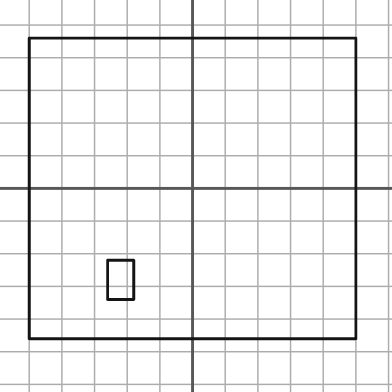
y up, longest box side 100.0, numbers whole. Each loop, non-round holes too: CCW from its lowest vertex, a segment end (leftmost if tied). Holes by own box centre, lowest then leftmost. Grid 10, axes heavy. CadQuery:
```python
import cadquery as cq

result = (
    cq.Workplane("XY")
    .moveTo(-50.0, -46.0)
    .lineTo(50.0, -46.0)
    .lineTo(50.0, 46.0)
    .lineTo(-50.0, 46.0)
    .close()
    .moveTo(-26.0, -34.0)
    .lineTo(-18.0, -34.0)
    .lineTo(-18.0, -22.0)
    .lineTo(-26.0, -22.0)
    .close()
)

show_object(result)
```